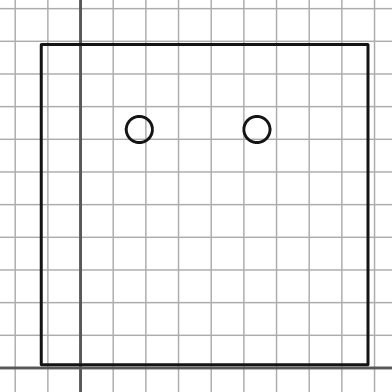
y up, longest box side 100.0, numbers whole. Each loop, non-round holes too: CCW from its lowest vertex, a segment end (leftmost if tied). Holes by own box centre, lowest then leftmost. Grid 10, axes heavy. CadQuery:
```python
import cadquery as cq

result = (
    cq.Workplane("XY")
    .moveTo(-12.0, 1.0)
    .lineTo(88.0, 1.0)
    .lineTo(88.0, 99.0)
    .lineTo(-12.0, 99.0)
    .close()
    .moveTo(18.0, 73.0)
    .circle(4.0)
    .moveTo(54.0, 73.0)
    .circle(4.0)
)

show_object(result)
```